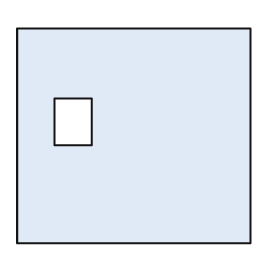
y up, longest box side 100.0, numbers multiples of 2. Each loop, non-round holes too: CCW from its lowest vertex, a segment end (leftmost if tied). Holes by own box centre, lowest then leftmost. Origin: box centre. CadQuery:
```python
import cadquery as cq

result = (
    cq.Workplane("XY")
    .moveTo(-50.0, -46.0)
    .lineTo(50.0, -46.0)
    .lineTo(50.0, 46.0)
    .lineTo(-50.0, 46.0)
    .close()
    .moveTo(-34.0, -4.0)
    .lineTo(-18.0, -4.0)
    .lineTo(-18.0, 16.0)
    .lineTo(-34.0, 16.0)
    .close()
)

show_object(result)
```